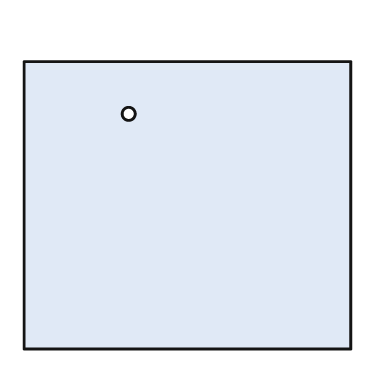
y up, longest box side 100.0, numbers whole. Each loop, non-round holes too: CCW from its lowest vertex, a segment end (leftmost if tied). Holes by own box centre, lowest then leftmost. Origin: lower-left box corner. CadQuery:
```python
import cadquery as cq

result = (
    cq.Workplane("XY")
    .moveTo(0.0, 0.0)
    .lineTo(100.0, 0.0)
    .lineTo(100.0, 88.0)
    .lineTo(0.0, 88.0)
    .close()
    .moveTo(32.0, 72.0)
    .circle(2.0)
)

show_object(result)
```